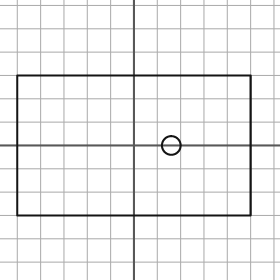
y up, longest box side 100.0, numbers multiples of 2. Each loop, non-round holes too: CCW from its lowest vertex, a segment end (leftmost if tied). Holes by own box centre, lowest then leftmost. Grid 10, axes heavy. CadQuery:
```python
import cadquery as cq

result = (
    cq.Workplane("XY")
    .moveTo(-50.0, -30.0)
    .lineTo(50.0, -30.0)
    .lineTo(50.0, 30.0)
    .lineTo(-50.0, 30.0)
    .close()
    .moveTo(16.0, 0.0)
    .circle(4.0)
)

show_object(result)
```